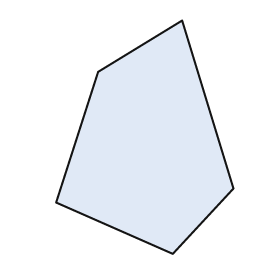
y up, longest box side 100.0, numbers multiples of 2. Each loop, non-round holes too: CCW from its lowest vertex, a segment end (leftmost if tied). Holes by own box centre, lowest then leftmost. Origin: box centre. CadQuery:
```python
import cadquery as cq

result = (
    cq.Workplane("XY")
    .moveTo(12.0, -50.0)
    .lineTo(38.0, -22.0)
    .lineTo(16.0, 50.0)
    .lineTo(-20.0, 28.0)
    .lineTo(-38.0, -28.0)
    .close()
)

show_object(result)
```